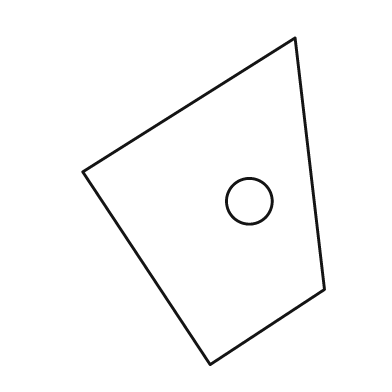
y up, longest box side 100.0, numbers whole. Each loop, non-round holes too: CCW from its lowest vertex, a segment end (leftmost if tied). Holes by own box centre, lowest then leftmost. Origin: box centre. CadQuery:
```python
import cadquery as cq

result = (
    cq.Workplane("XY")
    .moveTo(2.0, -50.0)
    .lineTo(37.0, -27.0)
    .lineTo(28.0, 50.0)
    .lineTo(-37.0, 9.0)
    .close()
    .moveTo(14.0, 0.0)
    .circle(7.0)
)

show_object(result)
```